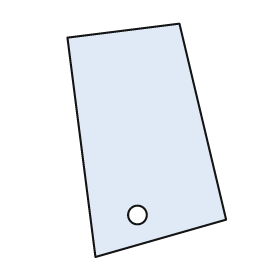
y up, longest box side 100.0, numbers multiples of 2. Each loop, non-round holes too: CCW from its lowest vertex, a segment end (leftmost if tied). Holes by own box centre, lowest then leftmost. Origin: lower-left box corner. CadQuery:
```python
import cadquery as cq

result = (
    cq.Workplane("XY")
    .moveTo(12.0, 0.0)
    .lineTo(68.0, 16.0)
    .lineTo(48.0, 100.0)
    .lineTo(0.0, 94.0)
    .close()
    .moveTo(30.0, 18.0)
    .circle(4.0)
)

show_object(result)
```